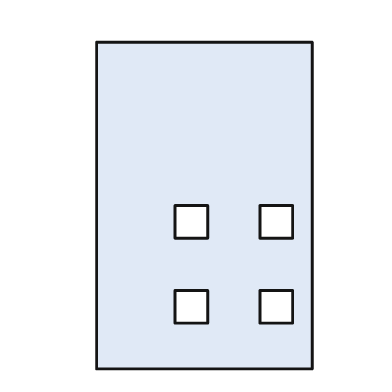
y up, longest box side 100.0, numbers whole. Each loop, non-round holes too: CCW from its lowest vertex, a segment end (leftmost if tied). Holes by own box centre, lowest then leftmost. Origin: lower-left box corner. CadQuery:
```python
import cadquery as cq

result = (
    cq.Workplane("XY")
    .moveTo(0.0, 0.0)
    .lineTo(66.0, 0.0)
    .lineTo(66.0, 100.0)
    .lineTo(0.0, 100.0)
    .close()
    .moveTo(24.0, 14.0)
    .lineTo(34.0, 14.0)
    .lineTo(34.0, 24.0)
    .lineTo(24.0, 24.0)
    .close()
    .moveTo(50.0, 14.0)
    .lineTo(60.0, 14.0)
    .lineTo(60.0, 24.0)
    .lineTo(50.0, 24.0)
    .close()
    .moveTo(24.0, 40.0)
    .lineTo(34.0, 40.0)
    .lineTo(34.0, 50.0)
    .lineTo(24.0, 50.0)
    .close()
    .moveTo(50.0, 40.0)
    .lineTo(60.0, 40.0)
    .lineTo(60.0, 50.0)
    .lineTo(50.0, 50.0)
    .close()
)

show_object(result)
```